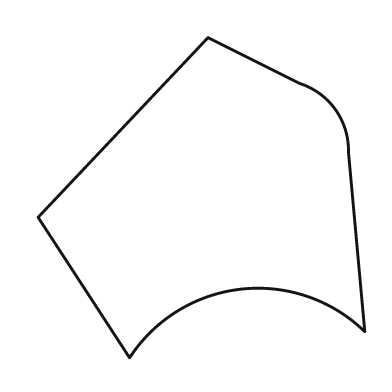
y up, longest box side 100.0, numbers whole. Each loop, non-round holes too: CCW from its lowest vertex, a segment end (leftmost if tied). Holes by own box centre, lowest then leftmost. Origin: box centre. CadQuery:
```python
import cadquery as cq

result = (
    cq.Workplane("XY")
    .moveTo(-22.0, -49.0)
    .threePointArc((12.0, -28.0), (50.0, -41.0))
    .lineTo(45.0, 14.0)
    .threePointArc((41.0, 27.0), (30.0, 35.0))
    .lineTo(2.0, 49.0)
    .lineTo(-50.0, -6.0)
    .close()
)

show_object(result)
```